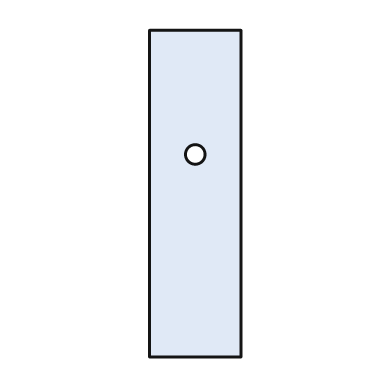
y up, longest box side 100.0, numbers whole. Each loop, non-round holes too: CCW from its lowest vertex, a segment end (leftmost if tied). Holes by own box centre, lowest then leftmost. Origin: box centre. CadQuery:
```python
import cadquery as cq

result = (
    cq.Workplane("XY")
    .moveTo(-14.0, -50.0)
    .lineTo(14.0, -50.0)
    .lineTo(14.0, 50.0)
    .lineTo(-14.0, 50.0)
    .close()
    .moveTo(0.0, 12.0)
    .circle(3.0)
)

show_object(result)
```